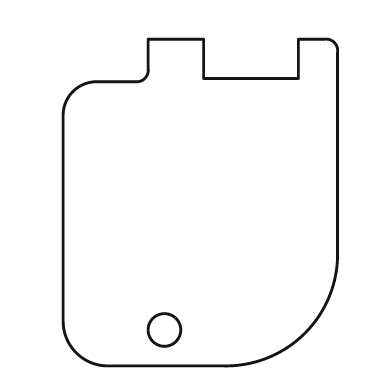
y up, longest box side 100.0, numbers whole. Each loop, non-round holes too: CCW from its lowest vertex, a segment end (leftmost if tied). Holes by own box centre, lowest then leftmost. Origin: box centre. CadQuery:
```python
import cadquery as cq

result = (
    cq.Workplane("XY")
    .moveTo(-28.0, -50.0)
    .lineTo(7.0, -50.0)
    .threePointArc((32.0, -40.0), (42.0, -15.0))
    .lineTo(42.0, 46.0)
    .threePointArc((41.0, 49.0), (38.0, 50.0))
    .lineTo(30.0, 50.0)
    .lineTo(30.0, 38.0)
    .lineTo(1.0, 38.0)
    .lineTo(1.0, 50.0)
    .lineTo(-16.0, 50.0)
    .lineTo(-16.0, 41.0)
    .threePointArc((-17.0, 38.0), (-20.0, 37.0))
    .lineTo(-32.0, 37.0)
    .threePointArc((-39.0, 34.0), (-42.0, 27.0))
    .lineTo(-42.0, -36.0)
    .threePointArc((-38.0, -46.0), (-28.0, -50.0))
    .close()
    .moveTo(-11.0, -39.0)
    .circle(5.0)
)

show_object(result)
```